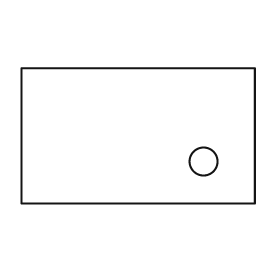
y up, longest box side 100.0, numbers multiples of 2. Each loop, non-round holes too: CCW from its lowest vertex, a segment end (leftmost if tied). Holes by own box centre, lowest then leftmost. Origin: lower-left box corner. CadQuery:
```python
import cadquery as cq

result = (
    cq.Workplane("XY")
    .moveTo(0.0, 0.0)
    .lineTo(100.0, 0.0)
    .lineTo(100.0, 58.0)
    .lineTo(0.0, 58.0)
    .close()
    .moveTo(78.0, 18.0)
    .circle(6.0)
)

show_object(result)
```